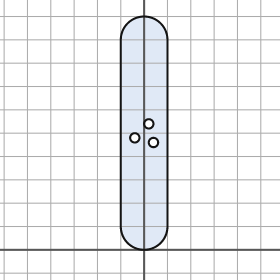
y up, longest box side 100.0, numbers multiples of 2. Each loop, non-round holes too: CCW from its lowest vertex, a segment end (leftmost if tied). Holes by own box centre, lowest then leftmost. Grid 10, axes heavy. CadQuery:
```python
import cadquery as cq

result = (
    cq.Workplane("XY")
    .moveTo(-10.0, 10.0)
    .threePointArc((0.0, 0.0), (10.0, 10.0))
    .lineTo(10.0, 90.0)
    .threePointArc((0.0, 100.0), (-10.0, 90.0))
    .close()
    .moveTo(4.0, 46.0)
    .circle(2.0)
    .moveTo(-4.0, 48.0)
    .circle(2.0)
    .moveTo(2.0, 54.0)
    .circle(2.0)
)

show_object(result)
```